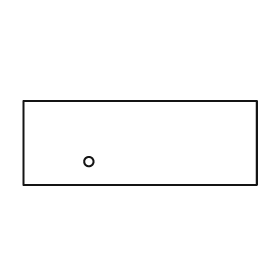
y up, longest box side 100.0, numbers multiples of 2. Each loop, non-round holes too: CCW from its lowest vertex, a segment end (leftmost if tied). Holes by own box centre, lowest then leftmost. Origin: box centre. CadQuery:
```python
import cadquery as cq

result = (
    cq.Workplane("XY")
    .moveTo(-50.0, -18.0)
    .lineTo(50.0, -18.0)
    .lineTo(50.0, 18.0)
    .lineTo(-50.0, 18.0)
    .close()
    .moveTo(-22.0, -8.0)
    .circle(2.0)
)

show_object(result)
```